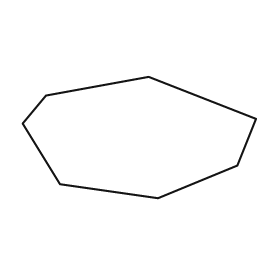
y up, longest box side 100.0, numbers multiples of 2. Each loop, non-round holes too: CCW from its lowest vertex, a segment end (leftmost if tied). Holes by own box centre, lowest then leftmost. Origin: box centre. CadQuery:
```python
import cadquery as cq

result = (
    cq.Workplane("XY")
    .moveTo(8.0, -26.0)
    .lineTo(42.0, -12.0)
    .lineTo(50.0, 8.0)
    .lineTo(4.0, 26.0)
    .lineTo(-40.0, 18.0)
    .lineTo(-50.0, 6.0)
    .lineTo(-34.0, -20.0)
    .close()
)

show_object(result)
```